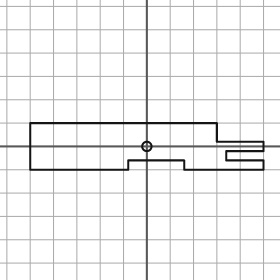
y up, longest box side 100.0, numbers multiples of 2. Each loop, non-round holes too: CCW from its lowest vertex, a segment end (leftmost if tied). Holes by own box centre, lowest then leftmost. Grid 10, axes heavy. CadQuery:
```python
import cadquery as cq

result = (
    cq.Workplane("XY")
    .moveTo(-50.0, -10.0)
    .lineTo(-8.0, -10.0)
    .lineTo(-8.0, -6.0)
    .lineTo(16.0, -6.0)
    .lineTo(16.0, -10.0)
    .lineTo(50.0, -10.0)
    .lineTo(50.0, -6.0)
    .lineTo(34.0, -6.0)
    .lineTo(34.0, -2.0)
    .lineTo(50.0, -2.0)
    .lineTo(50.0, 2.0)
    .lineTo(30.0, 2.0)
    .lineTo(30.0, 10.0)
    .lineTo(-50.0, 10.0)
    .close()
    .moveTo(0.0, 0.0)
    .circle(2.0)
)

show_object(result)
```